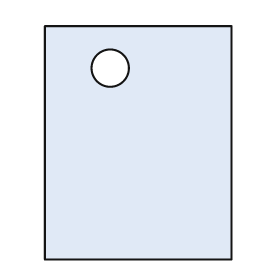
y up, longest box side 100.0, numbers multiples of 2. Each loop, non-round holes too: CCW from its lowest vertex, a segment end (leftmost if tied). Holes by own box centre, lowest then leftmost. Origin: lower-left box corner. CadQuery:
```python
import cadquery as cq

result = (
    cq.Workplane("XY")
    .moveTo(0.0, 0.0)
    .lineTo(80.0, 0.0)
    .lineTo(80.0, 100.0)
    .lineTo(0.0, 100.0)
    .close()
    .moveTo(28.0, 82.0)
    .circle(8.0)
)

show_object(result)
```